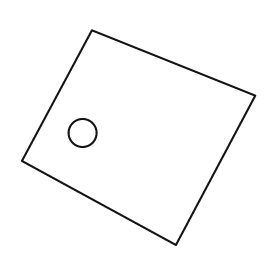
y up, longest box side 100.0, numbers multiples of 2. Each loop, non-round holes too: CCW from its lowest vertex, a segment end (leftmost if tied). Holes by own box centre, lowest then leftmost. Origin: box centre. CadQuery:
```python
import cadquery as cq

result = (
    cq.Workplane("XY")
    .moveTo(16.0, -46.0)
    .lineTo(50.0, 18.0)
    .lineTo(-20.0, 46.0)
    .lineTo(-50.0, -10.0)
    .close()
    .moveTo(-24.0, 2.0)
    .circle(6.0)
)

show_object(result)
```